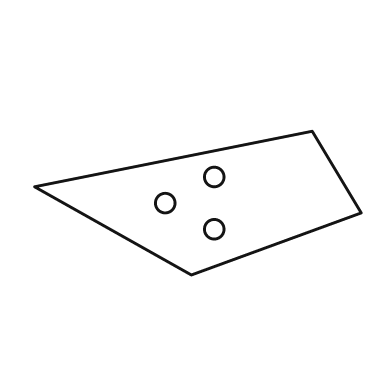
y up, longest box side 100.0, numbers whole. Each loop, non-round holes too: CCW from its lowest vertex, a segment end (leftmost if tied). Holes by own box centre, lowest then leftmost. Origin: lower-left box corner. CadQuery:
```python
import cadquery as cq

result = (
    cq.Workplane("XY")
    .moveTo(48.0, 0.0)
    .lineTo(100.0, 19.0)
    .lineTo(85.0, 44.0)
    .lineTo(0.0, 27.0)
    .close()
    .moveTo(55.0, 14.0)
    .circle(3.0)
    .moveTo(40.0, 22.0)
    .circle(3.0)
    .moveTo(55.0, 30.0)
    .circle(3.0)
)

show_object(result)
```